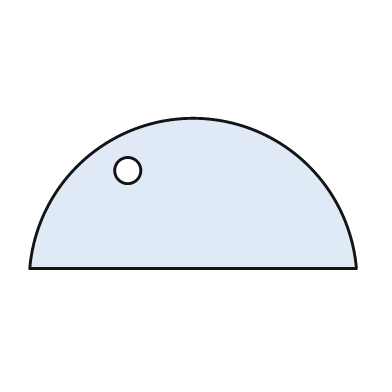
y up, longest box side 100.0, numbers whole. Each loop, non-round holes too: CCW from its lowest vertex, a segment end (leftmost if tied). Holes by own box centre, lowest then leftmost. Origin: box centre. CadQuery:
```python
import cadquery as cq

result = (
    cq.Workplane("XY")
    .moveTo(-50.0, -23.0)
    .lineTo(50.0, -23.0)
    .threePointArc((0.0, 23.0), (-50.0, -23.0))
    .close()
    .moveTo(-20.0, 7.0)
    .circle(4.0)
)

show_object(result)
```